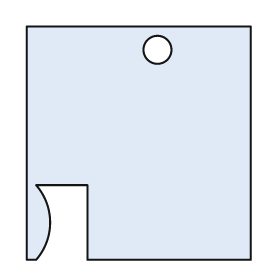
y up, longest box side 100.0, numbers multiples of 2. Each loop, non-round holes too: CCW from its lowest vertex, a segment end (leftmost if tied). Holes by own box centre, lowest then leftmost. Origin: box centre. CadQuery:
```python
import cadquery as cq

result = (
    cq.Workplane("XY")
    .moveTo(-48.0, -50.0)
    .lineTo(-44.0, -50.0)
    .threePointArc((-38.0, -34.0), (-44.0, -18.0))
    .lineTo(-22.0, -18.0)
    .lineTo(-22.0, -50.0)
    .lineTo(48.0, -50.0)
    .lineTo(48.0, 50.0)
    .lineTo(-48.0, 50.0)
    .close()
    .moveTo(8.0, 40.0)
    .circle(6.0)
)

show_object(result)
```